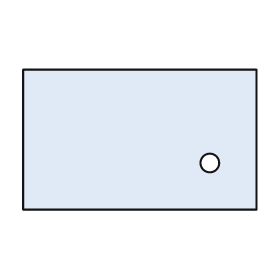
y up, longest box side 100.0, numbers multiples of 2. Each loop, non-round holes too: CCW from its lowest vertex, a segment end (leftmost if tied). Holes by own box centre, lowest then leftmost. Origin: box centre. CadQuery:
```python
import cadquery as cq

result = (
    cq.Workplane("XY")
    .moveTo(-50.0, -30.0)
    .lineTo(50.0, -30.0)
    .lineTo(50.0, 30.0)
    .lineTo(-50.0, 30.0)
    .close()
    .moveTo(30.0, -10.0)
    .circle(4.0)
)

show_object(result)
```